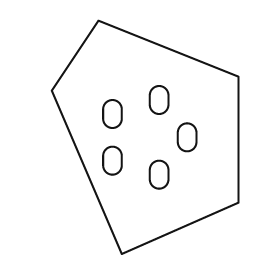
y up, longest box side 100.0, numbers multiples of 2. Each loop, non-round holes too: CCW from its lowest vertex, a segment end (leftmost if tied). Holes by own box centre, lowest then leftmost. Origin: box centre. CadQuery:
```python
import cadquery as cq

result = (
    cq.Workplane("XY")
    .moveTo(-10.0, -50.0)
    .lineTo(40.0, -28.0)
    .lineTo(40.0, 26.0)
    .lineTo(-20.0, 50.0)
    .lineTo(-40.0, 20.0)
    .close()
    .moveTo(2.0, -18.0)
    .threePointArc((6.0, -22.0), (10.0, -18.0))
    .lineTo(10.0, -14.0)
    .threePointArc((6.0, -10.0), (2.0, -14.0))
    .close()
    .moveTo(-18.0, -12.0)
    .threePointArc((-14.0, -16.0), (-10.0, -12.0))
    .lineTo(-10.0, -8.0)
    .threePointArc((-14.0, -4.0), (-18.0, -8.0))
    .close()
    .moveTo(14.0, -2.0)
    .threePointArc((18.0, -6.0), (22.0, -2.0))
    .lineTo(22.0, 2.0)
    .threePointArc((18.0, 6.0), (14.0, 2.0))
    .close()
    .moveTo(-18.0, 8.0)
    .threePointArc((-14.0, 4.0), (-10.0, 8.0))
    .lineTo(-10.0, 12.0)
    .threePointArc((-14.0, 16.0), (-18.0, 12.0))
    .close()
    .moveTo(2.0, 14.0)
    .threePointArc((6.0, 10.0), (10.0, 14.0))
    .lineTo(10.0, 18.0)
    .threePointArc((6.0, 22.0), (2.0, 18.0))
    .close()
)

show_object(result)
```